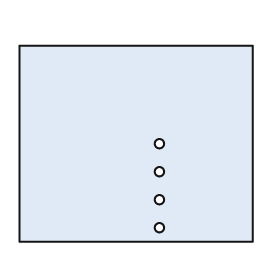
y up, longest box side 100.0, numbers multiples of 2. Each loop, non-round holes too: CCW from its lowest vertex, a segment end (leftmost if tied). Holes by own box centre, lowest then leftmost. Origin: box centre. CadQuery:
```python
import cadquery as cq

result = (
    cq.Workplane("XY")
    .moveTo(-50.0, -42.0)
    .lineTo(50.0, -42.0)
    .lineTo(50.0, 42.0)
    .lineTo(-50.0, 42.0)
    .close()
    .moveTo(10.0, -36.0)
    .circle(2.0)
    .moveTo(10.0, -24.0)
    .circle(2.0)
    .moveTo(10.0, -12.0)
    .circle(2.0)
    .moveTo(10.0, 0.0)
    .circle(2.0)
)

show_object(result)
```